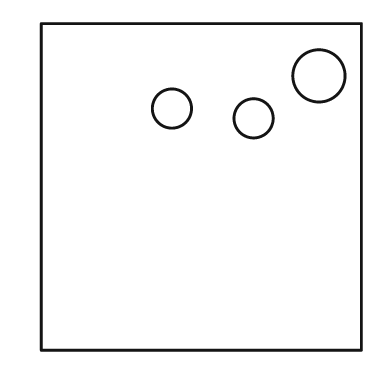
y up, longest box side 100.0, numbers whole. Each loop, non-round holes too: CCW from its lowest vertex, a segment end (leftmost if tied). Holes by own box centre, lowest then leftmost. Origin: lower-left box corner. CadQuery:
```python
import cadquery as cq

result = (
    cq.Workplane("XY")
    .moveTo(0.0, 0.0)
    .lineTo(98.0, 0.0)
    .lineTo(98.0, 100.0)
    .lineTo(0.0, 100.0)
    .close()
    .moveTo(65.0, 71.0)
    .circle(6.0)
    .moveTo(40.0, 74.0)
    .circle(6.0)
    .moveTo(85.0, 84.0)
    .circle(8.0)
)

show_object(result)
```